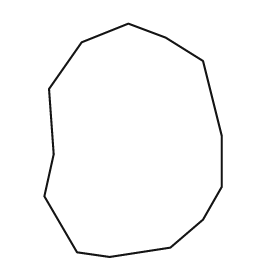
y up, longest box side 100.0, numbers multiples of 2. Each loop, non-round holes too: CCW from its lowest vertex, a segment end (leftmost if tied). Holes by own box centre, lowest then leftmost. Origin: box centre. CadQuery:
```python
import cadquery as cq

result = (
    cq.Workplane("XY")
    .moveTo(-10.0, -50.0)
    .lineTo(16.0, -46.0)
    .lineTo(30.0, -34.0)
    .lineTo(38.0, -20.0)
    .lineTo(38.0, 2.0)
    .lineTo(30.0, 34.0)
    .lineTo(14.0, 44.0)
    .lineTo(-2.0, 50.0)
    .lineTo(-22.0, 42.0)
    .lineTo(-36.0, 22.0)
    .lineTo(-34.0, -6.0)
    .lineTo(-38.0, -24.0)
    .lineTo(-24.0, -48.0)
    .close()
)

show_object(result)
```